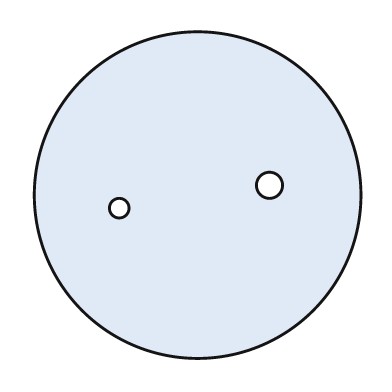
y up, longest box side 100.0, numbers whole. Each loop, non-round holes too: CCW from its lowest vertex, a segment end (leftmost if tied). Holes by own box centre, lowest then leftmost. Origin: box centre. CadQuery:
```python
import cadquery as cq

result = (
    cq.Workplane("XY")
    .moveTo(0.0, 0.0)
    .circle(50.0)
    .moveTo(-24.0, -4.0)
    .circle(3.0)
    .moveTo(22.0, 3.0)
    .circle(4.0)
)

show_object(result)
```